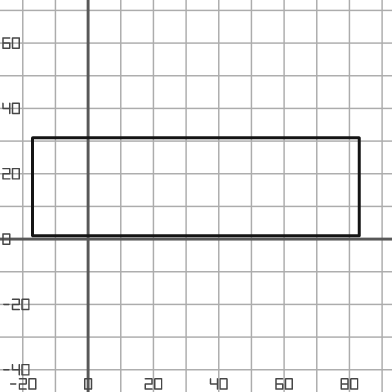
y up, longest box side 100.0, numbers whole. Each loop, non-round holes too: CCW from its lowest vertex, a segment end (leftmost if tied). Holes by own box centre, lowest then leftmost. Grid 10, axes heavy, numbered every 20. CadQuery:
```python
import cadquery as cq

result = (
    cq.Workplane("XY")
    .moveTo(-17.0, 1.0)
    .lineTo(83.0, 1.0)
    .lineTo(83.0, 31.0)
    .lineTo(-17.0, 31.0)
    .close()
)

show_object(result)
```